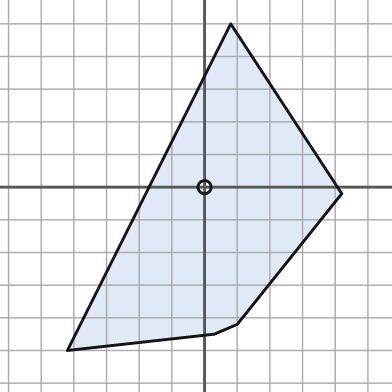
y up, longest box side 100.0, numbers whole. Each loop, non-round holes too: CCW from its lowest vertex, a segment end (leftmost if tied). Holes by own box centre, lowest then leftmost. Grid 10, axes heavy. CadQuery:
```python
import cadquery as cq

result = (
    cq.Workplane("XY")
    .moveTo(-42.0, -50.0)
    .lineTo(3.0, -45.0)
    .lineTo(10.0, -42.0)
    .lineTo(42.0, -2.0)
    .lineTo(8.0, 50.0)
    .close()
    .moveTo(0.0, 0.0)
    .circle(2.0)
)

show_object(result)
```